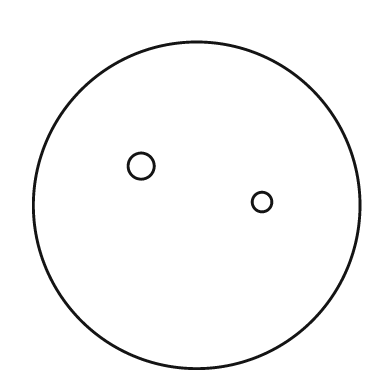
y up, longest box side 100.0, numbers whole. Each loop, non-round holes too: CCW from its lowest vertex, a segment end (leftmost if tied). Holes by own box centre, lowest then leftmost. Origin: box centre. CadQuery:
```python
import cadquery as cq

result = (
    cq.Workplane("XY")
    .moveTo(0.0, 0.0)
    .circle(50.0)
    .moveTo(20.0, 1.0)
    .circle(3.0)
    .moveTo(-17.0, 12.0)
    .circle(4.0)
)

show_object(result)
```